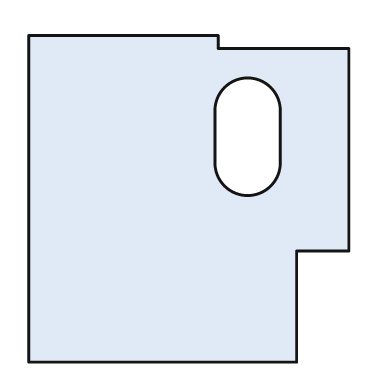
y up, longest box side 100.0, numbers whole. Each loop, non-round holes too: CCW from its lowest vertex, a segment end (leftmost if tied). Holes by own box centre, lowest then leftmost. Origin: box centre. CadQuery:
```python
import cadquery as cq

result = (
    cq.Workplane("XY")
    .moveTo(-49.0, -50.0)
    .lineTo(33.0, -50.0)
    .lineTo(33.0, -16.0)
    .lineTo(49.0, -16.0)
    .lineTo(49.0, 46.0)
    .lineTo(9.0, 46.0)
    .lineTo(9.0, 50.0)
    .lineTo(-49.0, 50.0)
    .close()
    .moveTo(8.0, 11.0)
    .threePointArc((18.0, 1.0), (28.0, 11.0))
    .lineTo(28.0, 27.0)
    .threePointArc((18.0, 37.0), (8.0, 27.0))
    .close()
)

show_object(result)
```